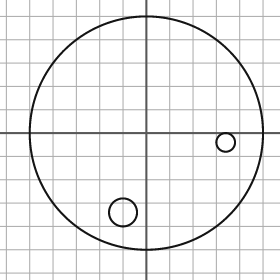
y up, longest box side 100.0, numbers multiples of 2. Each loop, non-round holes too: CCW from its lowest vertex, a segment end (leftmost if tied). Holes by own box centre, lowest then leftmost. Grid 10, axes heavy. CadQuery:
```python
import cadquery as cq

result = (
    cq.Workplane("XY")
    .moveTo(0.0, 0.0)
    .circle(50.0)
    .moveTo(-10.0, -34.0)
    .circle(6.0)
    .moveTo(34.0, -4.0)
    .circle(4.0)
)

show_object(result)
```